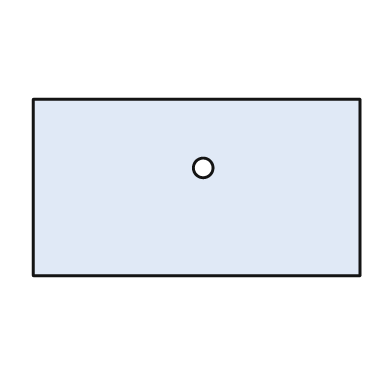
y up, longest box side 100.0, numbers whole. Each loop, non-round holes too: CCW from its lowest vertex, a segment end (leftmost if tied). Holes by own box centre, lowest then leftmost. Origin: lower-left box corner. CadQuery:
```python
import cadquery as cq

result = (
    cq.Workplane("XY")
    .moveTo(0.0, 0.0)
    .lineTo(100.0, 0.0)
    .lineTo(100.0, 54.0)
    .lineTo(0.0, 54.0)
    .close()
    .moveTo(52.0, 33.0)
    .circle(3.0)
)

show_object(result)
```